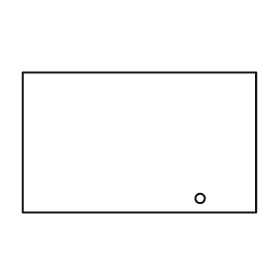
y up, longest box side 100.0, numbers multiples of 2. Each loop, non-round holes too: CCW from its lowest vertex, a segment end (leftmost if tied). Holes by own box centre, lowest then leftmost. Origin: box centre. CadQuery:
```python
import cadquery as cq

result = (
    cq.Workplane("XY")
    .moveTo(-50.0, -30.0)
    .lineTo(50.0, -30.0)
    .lineTo(50.0, 30.0)
    .lineTo(-50.0, 30.0)
    .close()
    .moveTo(26.0, -24.0)
    .circle(2.0)
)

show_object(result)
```